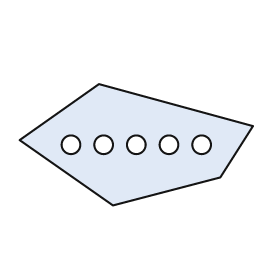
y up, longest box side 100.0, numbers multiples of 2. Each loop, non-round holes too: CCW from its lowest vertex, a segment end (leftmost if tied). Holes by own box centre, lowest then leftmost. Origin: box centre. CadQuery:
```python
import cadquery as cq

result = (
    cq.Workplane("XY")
    .moveTo(-10.0, -26.0)
    .lineTo(36.0, -14.0)
    .lineTo(50.0, 8.0)
    .lineTo(-16.0, 26.0)
    .lineTo(-50.0, 2.0)
    .close()
    .moveTo(-28.0, 0.0)
    .circle(4.0)
    .moveTo(-14.0, 0.0)
    .circle(4.0)
    .moveTo(0.0, 0.0)
    .circle(4.0)
    .moveTo(14.0, 0.0)
    .circle(4.0)
    .moveTo(28.0, 0.0)
    .circle(4.0)
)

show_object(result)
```